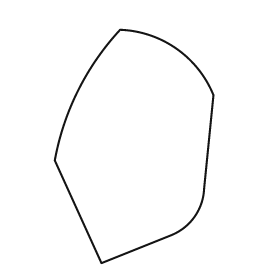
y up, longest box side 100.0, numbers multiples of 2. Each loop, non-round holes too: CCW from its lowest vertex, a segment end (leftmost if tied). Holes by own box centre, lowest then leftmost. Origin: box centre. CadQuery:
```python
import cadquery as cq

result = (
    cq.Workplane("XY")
    .moveTo(-14.0, -50.0)
    .lineTo(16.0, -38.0)
    .threePointArc((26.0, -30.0), (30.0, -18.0))
    .lineTo(34.0, 22.0)
    .threePointArc((18.0, 42.0), (-6.0, 50.0))
    .threePointArc((-24.0, 24.0), (-34.0, -6.0))
    .close()
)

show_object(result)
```